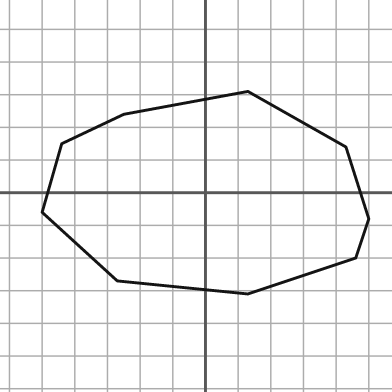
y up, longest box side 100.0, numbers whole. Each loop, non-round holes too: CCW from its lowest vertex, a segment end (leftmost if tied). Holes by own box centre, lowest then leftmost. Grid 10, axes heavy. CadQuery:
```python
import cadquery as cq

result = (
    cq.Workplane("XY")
    .moveTo(13.0, -31.0)
    .lineTo(46.0, -20.0)
    .lineTo(50.0, -8.0)
    .lineTo(43.0, 14.0)
    .lineTo(13.0, 31.0)
    .lineTo(-25.0, 24.0)
    .lineTo(-44.0, 15.0)
    .lineTo(-50.0, -6.0)
    .lineTo(-27.0, -27.0)
    .close()
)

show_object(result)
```